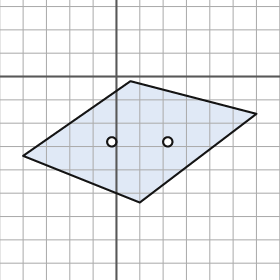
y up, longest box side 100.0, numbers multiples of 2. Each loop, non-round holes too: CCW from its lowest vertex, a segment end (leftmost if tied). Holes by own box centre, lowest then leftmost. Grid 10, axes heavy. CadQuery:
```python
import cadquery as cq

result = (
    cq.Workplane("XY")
    .moveTo(10.0, -54.0)
    .lineTo(60.0, -16.0)
    .lineTo(6.0, -2.0)
    .lineTo(-40.0, -34.0)
    .close()
    .moveTo(-2.0, -28.0)
    .circle(2.0)
    .moveTo(22.0, -28.0)
    .circle(2.0)
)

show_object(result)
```